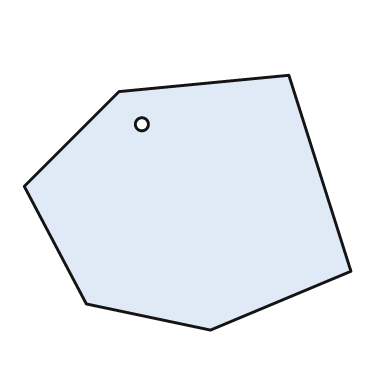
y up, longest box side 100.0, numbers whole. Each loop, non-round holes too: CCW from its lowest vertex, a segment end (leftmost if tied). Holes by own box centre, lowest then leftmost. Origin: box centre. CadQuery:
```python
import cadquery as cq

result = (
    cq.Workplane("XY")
    .moveTo(7.0, -39.0)
    .lineTo(50.0, -21.0)
    .lineTo(31.0, 39.0)
    .lineTo(-21.0, 34.0)
    .lineTo(-50.0, 5.0)
    .lineTo(-31.0, -31.0)
    .close()
    .moveTo(-14.0, 24.0)
    .circle(2.0)
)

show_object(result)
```